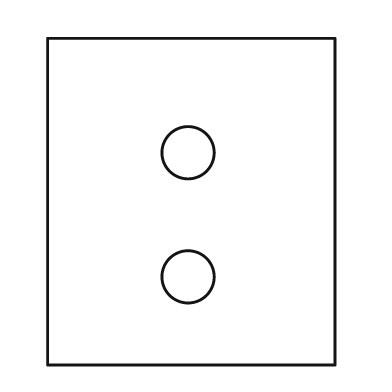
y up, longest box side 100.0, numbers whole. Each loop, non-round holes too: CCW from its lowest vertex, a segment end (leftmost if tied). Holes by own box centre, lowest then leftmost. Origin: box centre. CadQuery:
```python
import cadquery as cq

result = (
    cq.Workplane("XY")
    .moveTo(-44.0, -50.0)
    .lineTo(44.0, -50.0)
    .lineTo(44.0, 50.0)
    .lineTo(-44.0, 50.0)
    .close()
    .moveTo(-1.0, -23.0)
    .circle(8.0)
    .moveTo(-1.0, 15.0)
    .circle(8.0)
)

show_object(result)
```